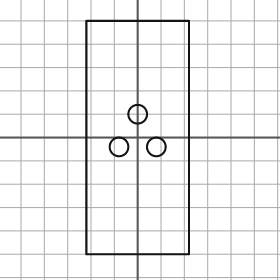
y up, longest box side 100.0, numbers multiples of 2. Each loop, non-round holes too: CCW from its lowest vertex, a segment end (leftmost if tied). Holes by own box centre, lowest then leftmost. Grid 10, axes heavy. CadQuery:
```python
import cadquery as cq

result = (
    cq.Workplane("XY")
    .moveTo(-22.0, -50.0)
    .lineTo(22.0, -50.0)
    .lineTo(22.0, 50.0)
    .lineTo(-22.0, 50.0)
    .close()
    .moveTo(-8.0, -4.0)
    .circle(4.0)
    .moveTo(8.0, -4.0)
    .circle(4.0)
    .moveTo(0.0, 10.0)
    .circle(4.0)
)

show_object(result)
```